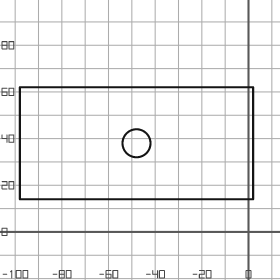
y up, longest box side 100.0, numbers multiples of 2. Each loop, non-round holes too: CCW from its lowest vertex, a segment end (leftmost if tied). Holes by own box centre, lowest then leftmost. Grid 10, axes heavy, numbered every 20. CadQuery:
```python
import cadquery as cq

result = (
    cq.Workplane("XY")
    .moveTo(-98.0, 14.0)
    .lineTo(2.0, 14.0)
    .lineTo(2.0, 62.0)
    .lineTo(-98.0, 62.0)
    .close()
    .moveTo(-48.0, 38.0)
    .circle(6.0)
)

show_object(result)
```